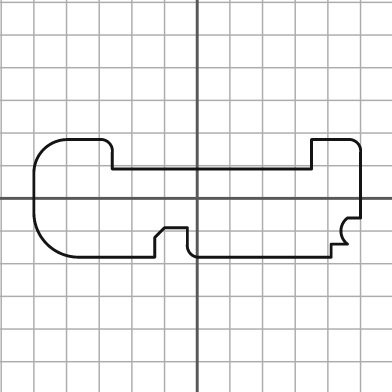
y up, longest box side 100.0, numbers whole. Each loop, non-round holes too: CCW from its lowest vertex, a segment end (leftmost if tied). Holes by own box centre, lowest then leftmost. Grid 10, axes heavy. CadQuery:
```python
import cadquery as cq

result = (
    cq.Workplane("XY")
    .moveTo(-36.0, -18.0)
    .lineTo(-13.0, -18.0)
    .lineTo(-13.0, -12.0)
    .lineTo(-10.0, -9.0)
    .lineTo(-3.0, -9.0)
    .lineTo(-3.0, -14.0)
    .threePointArc((-2.0, -17.0), (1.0, -18.0))
    .lineTo(41.0, -18.0)
    .lineTo(41.0, -14.0)
    .lineTo(46.0, -14.0)
    .threePointArc((44.0, -10.0), (46.0, -6.0))
    .lineTo(50.0, -6.0)
    .lineTo(50.0, 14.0)
    .threePointArc((49.0, 17.0), (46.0, 18.0))
    .lineTo(35.0, 18.0)
    .lineTo(35.0, 9.0)
    .lineTo(-26.0, 9.0)
    .lineTo(-26.0, 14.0)
    .threePointArc((-27.0, 17.0), (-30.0, 18.0))
    .lineTo(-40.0, 18.0)
    .threePointArc((-47.0, 15.0), (-50.0, 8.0))
    .lineTo(-50.0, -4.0)
    .threePointArc((-46.0, -14.0), (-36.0, -18.0))
    .close()
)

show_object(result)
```